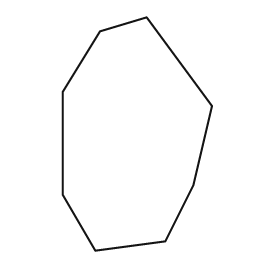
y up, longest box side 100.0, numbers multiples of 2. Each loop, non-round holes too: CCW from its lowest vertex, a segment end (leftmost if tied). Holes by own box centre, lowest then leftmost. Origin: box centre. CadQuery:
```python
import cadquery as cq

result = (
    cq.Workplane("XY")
    .moveTo(-18.0, -50.0)
    .lineTo(12.0, -46.0)
    .lineTo(24.0, -22.0)
    .lineTo(32.0, 12.0)
    .lineTo(4.0, 50.0)
    .lineTo(-16.0, 44.0)
    .lineTo(-32.0, 18.0)
    .lineTo(-32.0, -26.0)
    .close()
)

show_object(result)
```